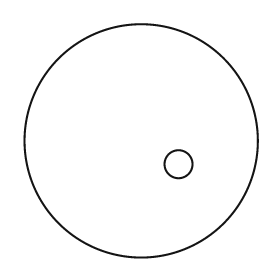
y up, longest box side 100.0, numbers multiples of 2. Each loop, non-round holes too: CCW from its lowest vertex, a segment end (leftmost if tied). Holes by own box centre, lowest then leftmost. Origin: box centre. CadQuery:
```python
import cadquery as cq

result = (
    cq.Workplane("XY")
    .moveTo(0.0, 0.0)
    .circle(50.0)
    .moveTo(16.0, -10.0)
    .circle(6.0)
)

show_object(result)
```